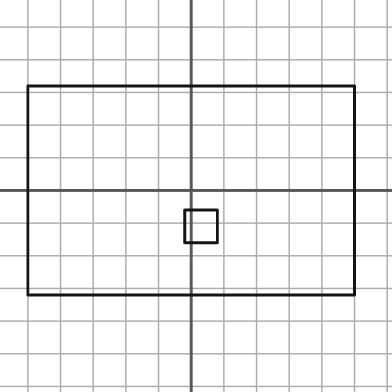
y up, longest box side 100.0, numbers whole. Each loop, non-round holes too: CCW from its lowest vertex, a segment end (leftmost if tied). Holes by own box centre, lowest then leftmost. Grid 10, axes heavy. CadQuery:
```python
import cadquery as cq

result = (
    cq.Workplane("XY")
    .moveTo(-50.0, -32.0)
    .lineTo(50.0, -32.0)
    .lineTo(50.0, 32.0)
    .lineTo(-50.0, 32.0)
    .close()
    .moveTo(-2.0, -16.0)
    .lineTo(8.0, -16.0)
    .lineTo(8.0, -6.0)
    .lineTo(-2.0, -6.0)
    .close()
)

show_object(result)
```